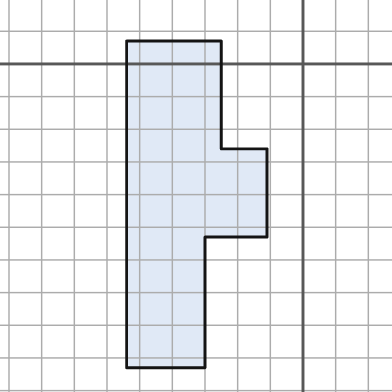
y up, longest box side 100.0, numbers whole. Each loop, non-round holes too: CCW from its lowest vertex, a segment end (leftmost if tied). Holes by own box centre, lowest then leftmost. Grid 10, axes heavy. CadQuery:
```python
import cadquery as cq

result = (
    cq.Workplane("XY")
    .moveTo(-54.0, -93.0)
    .lineTo(-30.0, -93.0)
    .lineTo(-30.0, -53.0)
    .lineTo(-11.0, -53.0)
    .lineTo(-11.0, -26.0)
    .lineTo(-25.0, -26.0)
    .lineTo(-25.0, 7.0)
    .lineTo(-54.0, 7.0)
    .close()
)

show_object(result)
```